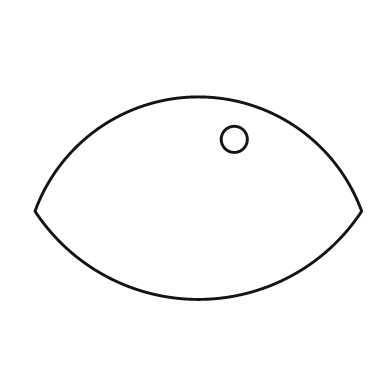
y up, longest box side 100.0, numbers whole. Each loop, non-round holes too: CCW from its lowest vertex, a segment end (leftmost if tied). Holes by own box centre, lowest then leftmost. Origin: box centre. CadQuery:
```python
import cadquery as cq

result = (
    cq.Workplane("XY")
    .moveTo(-50.0, -4.0)
    .threePointArc((0.0, -31.0), (50.0, -4.0))
    .threePointArc((0.0, 31.0), (-50.0, -4.0))
    .close()
    .moveTo(11.0, 18.0)
    .circle(4.0)
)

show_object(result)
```